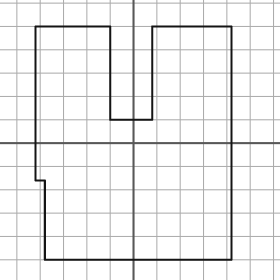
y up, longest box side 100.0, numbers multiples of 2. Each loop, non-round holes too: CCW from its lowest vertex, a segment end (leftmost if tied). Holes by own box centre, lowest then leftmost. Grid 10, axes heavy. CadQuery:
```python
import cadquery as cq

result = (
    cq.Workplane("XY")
    .moveTo(-38.0, -50.0)
    .lineTo(42.0, -50.0)
    .lineTo(42.0, 50.0)
    .lineTo(8.0, 50.0)
    .lineTo(8.0, 10.0)
    .lineTo(-10.0, 10.0)
    .lineTo(-10.0, 50.0)
    .lineTo(-42.0, 50.0)
    .lineTo(-42.0, -16.0)
    .lineTo(-38.0, -16.0)
    .close()
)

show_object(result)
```